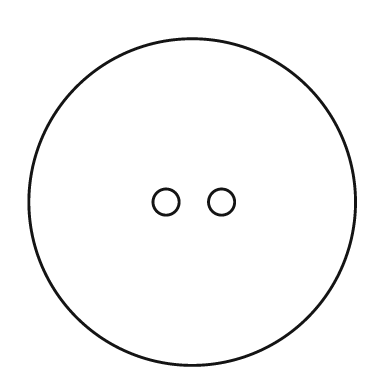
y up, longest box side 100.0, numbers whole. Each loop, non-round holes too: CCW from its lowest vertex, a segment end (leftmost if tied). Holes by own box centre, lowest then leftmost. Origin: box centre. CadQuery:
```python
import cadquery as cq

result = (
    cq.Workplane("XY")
    .moveTo(0.0, 0.0)
    .circle(50.0)
    .moveTo(-8.0, 0.0)
    .circle(4.0)
    .moveTo(9.0, 0.0)
    .circle(4.0)
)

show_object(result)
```